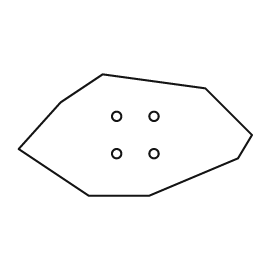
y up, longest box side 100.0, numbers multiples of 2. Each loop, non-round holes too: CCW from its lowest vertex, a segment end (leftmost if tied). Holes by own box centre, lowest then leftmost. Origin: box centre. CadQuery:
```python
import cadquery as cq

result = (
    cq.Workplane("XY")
    .moveTo(-20.0, -26.0)
    .lineTo(6.0, -26.0)
    .lineTo(44.0, -10.0)
    .lineTo(50.0, 0.0)
    .lineTo(30.0, 20.0)
    .lineTo(-14.0, 26.0)
    .lineTo(-32.0, 14.0)
    .lineTo(-50.0, -6.0)
    .close()
    .moveTo(-8.0, -8.0)
    .circle(2.0)
    .moveTo(8.0, -8.0)
    .circle(2.0)
    .moveTo(-8.0, 8.0)
    .circle(2.0)
    .moveTo(8.0, 8.0)
    .circle(2.0)
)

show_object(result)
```